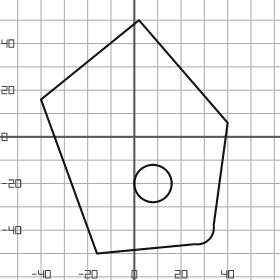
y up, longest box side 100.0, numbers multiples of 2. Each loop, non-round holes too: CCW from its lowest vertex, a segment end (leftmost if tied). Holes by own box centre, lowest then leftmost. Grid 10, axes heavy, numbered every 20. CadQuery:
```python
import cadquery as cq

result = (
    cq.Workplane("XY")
    .moveTo(-16.0, -50.0)
    .lineTo(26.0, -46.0)
    .threePointArc((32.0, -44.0), (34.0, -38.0))
    .lineTo(40.0, 6.0)
    .lineTo(2.0, 50.0)
    .lineTo(-40.0, 16.0)
    .close()
    .moveTo(8.0, -20.0)
    .circle(8.0)
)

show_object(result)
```